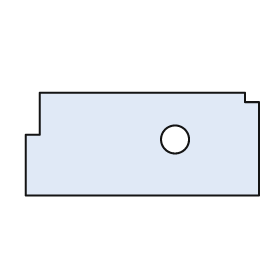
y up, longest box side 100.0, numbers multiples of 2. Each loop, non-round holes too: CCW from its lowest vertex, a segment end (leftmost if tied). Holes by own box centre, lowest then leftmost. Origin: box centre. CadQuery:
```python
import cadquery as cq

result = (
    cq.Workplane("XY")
    .moveTo(-50.0, -22.0)
    .lineTo(50.0, -22.0)
    .lineTo(50.0, 18.0)
    .lineTo(44.0, 18.0)
    .lineTo(44.0, 22.0)
    .lineTo(-44.0, 22.0)
    .lineTo(-44.0, 4.0)
    .lineTo(-50.0, 4.0)
    .close()
    .moveTo(14.0, 2.0)
    .circle(6.0)
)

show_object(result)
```